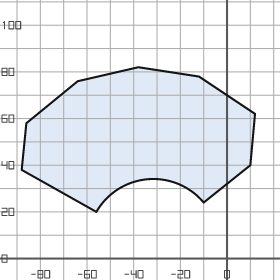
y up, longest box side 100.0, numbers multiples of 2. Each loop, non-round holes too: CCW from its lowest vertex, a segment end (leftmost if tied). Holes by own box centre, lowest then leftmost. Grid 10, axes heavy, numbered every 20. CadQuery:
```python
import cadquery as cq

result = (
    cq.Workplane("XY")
    .moveTo(-56.0, 20.0)
    .threePointArc((-34.0, 34.0), (-10.0, 24.0))
    .lineTo(10.0, 40.0)
    .lineTo(12.0, 62.0)
    .lineTo(-12.0, 78.0)
    .lineTo(-38.0, 82.0)
    .lineTo(-64.0, 76.0)
    .lineTo(-86.0, 58.0)
    .lineTo(-88.0, 38.0)
    .close()
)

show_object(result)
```